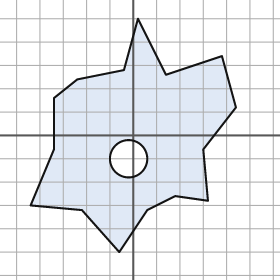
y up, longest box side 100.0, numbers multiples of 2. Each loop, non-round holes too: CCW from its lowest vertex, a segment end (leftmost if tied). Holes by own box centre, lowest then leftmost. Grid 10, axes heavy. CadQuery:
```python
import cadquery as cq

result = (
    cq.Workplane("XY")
    .moveTo(-6.0, -50.0)
    .lineTo(6.0, -32.0)
    .lineTo(18.0, -26.0)
    .lineTo(32.0, -28.0)
    .lineTo(30.0, -6.0)
    .lineTo(44.0, 12.0)
    .lineTo(38.0, 34.0)
    .lineTo(14.0, 26.0)
    .lineTo(2.0, 50.0)
    .lineTo(-4.0, 28.0)
    .lineTo(-24.0, 24.0)
    .lineTo(-34.0, 16.0)
    .lineTo(-34.0, -6.0)
    .lineTo(-44.0, -30.0)
    .lineTo(-22.0, -32.0)
    .close()
    .moveTo(-2.0, -10.0)
    .circle(8.0)
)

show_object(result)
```